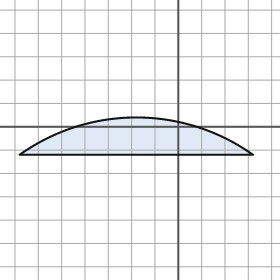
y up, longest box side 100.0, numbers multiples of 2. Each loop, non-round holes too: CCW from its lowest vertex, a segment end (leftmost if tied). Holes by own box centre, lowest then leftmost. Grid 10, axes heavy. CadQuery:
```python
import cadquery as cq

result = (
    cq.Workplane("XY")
    .moveTo(-68.0, -12.0)
    .lineTo(32.0, -12.0)
    .threePointArc((-18.0, 4.0), (-68.0, -12.0))
    .close()
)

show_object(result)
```